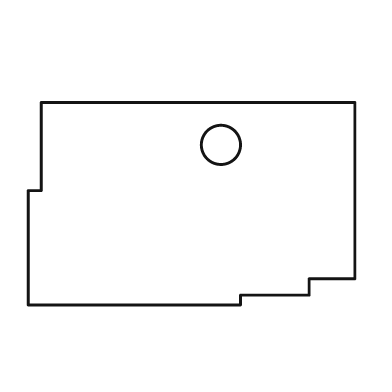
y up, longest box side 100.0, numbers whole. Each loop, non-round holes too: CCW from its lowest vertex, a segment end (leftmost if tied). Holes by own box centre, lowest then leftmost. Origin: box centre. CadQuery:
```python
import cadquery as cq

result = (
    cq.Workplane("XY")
    .moveTo(-50.0, -31.0)
    .lineTo(15.0, -31.0)
    .lineTo(15.0, -28.0)
    .lineTo(36.0, -28.0)
    .lineTo(36.0, -23.0)
    .lineTo(50.0, -23.0)
    .lineTo(50.0, 31.0)
    .lineTo(-46.0, 31.0)
    .lineTo(-46.0, 4.0)
    .lineTo(-50.0, 4.0)
    .close()
    .moveTo(9.0, 18.0)
    .circle(6.0)
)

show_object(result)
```